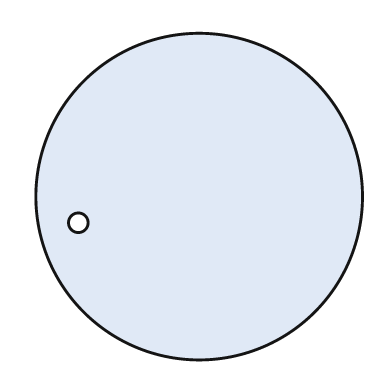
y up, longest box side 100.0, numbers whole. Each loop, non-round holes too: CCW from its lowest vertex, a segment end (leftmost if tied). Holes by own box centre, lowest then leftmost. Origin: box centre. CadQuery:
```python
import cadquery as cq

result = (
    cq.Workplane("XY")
    .moveTo(0.0, 0.0)
    .circle(50.0)
    .moveTo(-37.0, -8.0)
    .circle(3.0)
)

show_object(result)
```